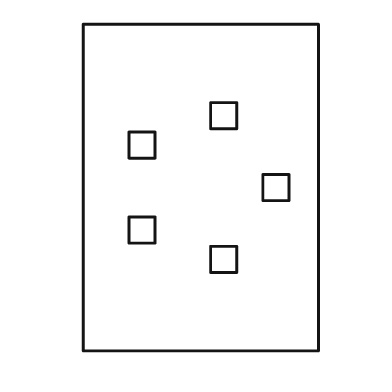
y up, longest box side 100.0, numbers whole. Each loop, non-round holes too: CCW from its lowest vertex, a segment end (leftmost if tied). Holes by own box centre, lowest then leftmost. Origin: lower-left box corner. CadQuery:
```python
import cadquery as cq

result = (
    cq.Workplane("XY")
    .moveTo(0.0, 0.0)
    .lineTo(72.0, 0.0)
    .lineTo(72.0, 100.0)
    .lineTo(0.0, 100.0)
    .close()
    .moveTo(39.0, 24.0)
    .lineTo(47.0, 24.0)
    .lineTo(47.0, 32.0)
    .lineTo(39.0, 32.0)
    .close()
    .moveTo(14.0, 33.0)
    .lineTo(22.0, 33.0)
    .lineTo(22.0, 41.0)
    .lineTo(14.0, 41.0)
    .close()
    .moveTo(55.0, 46.0)
    .lineTo(63.0, 46.0)
    .lineTo(63.0, 54.0)
    .lineTo(55.0, 54.0)
    .close()
    .moveTo(14.0, 59.0)
    .lineTo(22.0, 59.0)
    .lineTo(22.0, 67.0)
    .lineTo(14.0, 67.0)
    .close()
    .moveTo(39.0, 68.0)
    .lineTo(47.0, 68.0)
    .lineTo(47.0, 76.0)
    .lineTo(39.0, 76.0)
    .close()
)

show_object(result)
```